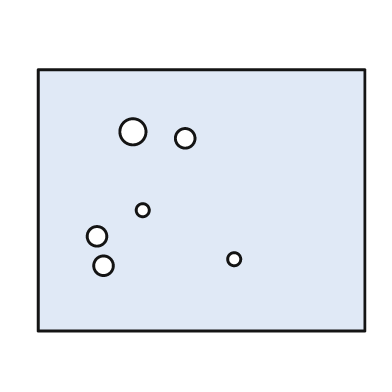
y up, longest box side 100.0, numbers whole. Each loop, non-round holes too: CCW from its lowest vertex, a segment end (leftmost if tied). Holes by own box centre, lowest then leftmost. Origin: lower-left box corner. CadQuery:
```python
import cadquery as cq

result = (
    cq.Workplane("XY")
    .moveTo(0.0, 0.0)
    .lineTo(100.0, 0.0)
    .lineTo(100.0, 80.0)
    .lineTo(0.0, 80.0)
    .close()
    .moveTo(20.0, 20.0)
    .circle(3.0)
    .moveTo(60.0, 22.0)
    .circle(2.0)
    .moveTo(18.0, 29.0)
    .circle(3.0)
    .moveTo(32.0, 37.0)
    .circle(2.0)
    .moveTo(45.0, 59.0)
    .circle(3.0)
    .moveTo(29.0, 61.0)
    .circle(4.0)
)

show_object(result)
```